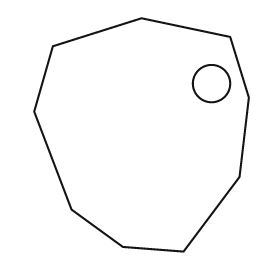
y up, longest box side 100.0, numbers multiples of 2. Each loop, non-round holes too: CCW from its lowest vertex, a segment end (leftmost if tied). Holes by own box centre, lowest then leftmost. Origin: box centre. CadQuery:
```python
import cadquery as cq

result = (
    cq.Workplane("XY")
    .moveTo(18.0, -50.0)
    .lineTo(42.0, -18.0)
    .lineTo(46.0, 16.0)
    .lineTo(38.0, 42.0)
    .lineTo(0.0, 50.0)
    .lineTo(-38.0, 38.0)
    .lineTo(-46.0, 10.0)
    .lineTo(-30.0, -32.0)
    .lineTo(-8.0, -48.0)
    .close()
    .moveTo(30.0, 22.0)
    .circle(8.0)
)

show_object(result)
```